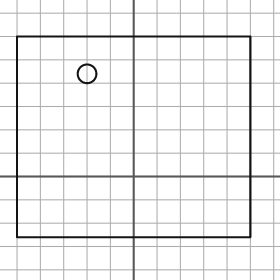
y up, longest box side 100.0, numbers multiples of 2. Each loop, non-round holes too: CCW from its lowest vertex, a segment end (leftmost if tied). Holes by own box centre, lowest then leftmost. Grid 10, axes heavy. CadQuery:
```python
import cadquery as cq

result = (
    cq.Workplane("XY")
    .moveTo(-50.0, -26.0)
    .lineTo(50.0, -26.0)
    .lineTo(50.0, 60.0)
    .lineTo(-50.0, 60.0)
    .close()
    .moveTo(-20.0, 44.0)
    .circle(4.0)
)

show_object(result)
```